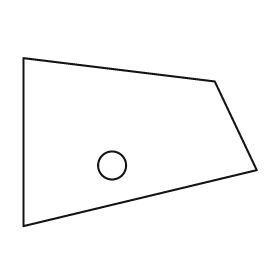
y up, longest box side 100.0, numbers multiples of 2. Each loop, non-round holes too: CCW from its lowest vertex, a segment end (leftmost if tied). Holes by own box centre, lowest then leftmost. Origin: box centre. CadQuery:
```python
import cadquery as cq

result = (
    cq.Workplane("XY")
    .moveTo(-50.0, -36.0)
    .lineTo(50.0, -12.0)
    .lineTo(32.0, 26.0)
    .lineTo(-50.0, 36.0)
    .close()
    .moveTo(-12.0, -10.0)
    .circle(6.0)
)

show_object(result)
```